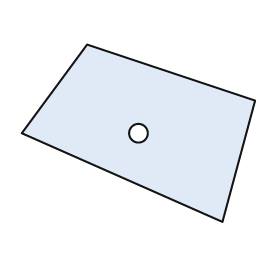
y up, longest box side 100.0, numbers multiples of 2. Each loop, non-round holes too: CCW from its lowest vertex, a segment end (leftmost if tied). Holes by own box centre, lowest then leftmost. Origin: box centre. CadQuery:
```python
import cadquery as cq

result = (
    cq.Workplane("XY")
    .moveTo(36.0, -38.0)
    .lineTo(50.0, 14.0)
    .lineTo(-22.0, 38.0)
    .lineTo(-50.0, 0.0)
    .close()
    .moveTo(0.0, 0.0)
    .circle(4.0)
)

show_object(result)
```